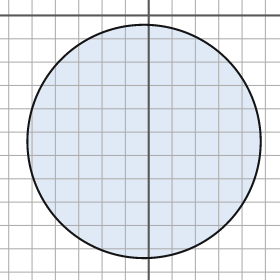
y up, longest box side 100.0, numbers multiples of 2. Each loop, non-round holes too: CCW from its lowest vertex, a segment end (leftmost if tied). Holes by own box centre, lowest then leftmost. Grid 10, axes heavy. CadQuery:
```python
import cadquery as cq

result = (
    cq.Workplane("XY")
    .moveTo(-2.0, -54.0)
    .circle(50.0)
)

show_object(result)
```